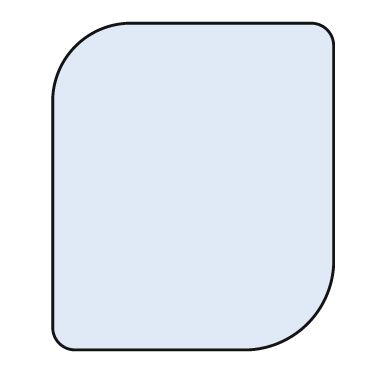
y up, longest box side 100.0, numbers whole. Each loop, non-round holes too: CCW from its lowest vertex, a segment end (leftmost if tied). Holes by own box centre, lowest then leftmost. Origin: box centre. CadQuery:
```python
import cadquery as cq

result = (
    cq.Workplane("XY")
    .moveTo(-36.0, -50.0)
    .lineTo(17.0, -50.0)
    .threePointArc((35.0, -42.0), (43.0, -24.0))
    .lineTo(43.0, 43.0)
    .threePointArc((41.0, 48.0), (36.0, 50.0))
    .lineTo(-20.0, 50.0)
    .threePointArc((-36.0, 43.0), (-43.0, 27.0))
    .lineTo(-43.0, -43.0)
    .threePointArc((-41.0, -48.0), (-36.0, -50.0))
    .close()
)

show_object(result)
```